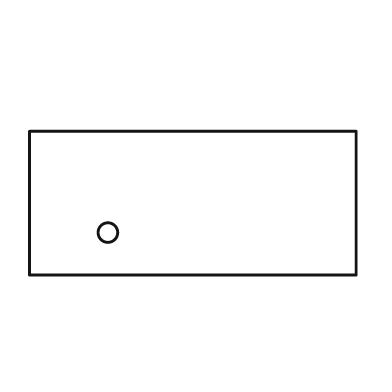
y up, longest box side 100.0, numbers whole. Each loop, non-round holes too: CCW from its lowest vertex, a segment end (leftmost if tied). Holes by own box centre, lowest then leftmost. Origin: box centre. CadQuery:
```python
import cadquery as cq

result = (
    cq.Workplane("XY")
    .moveTo(-50.0, -22.0)
    .lineTo(50.0, -22.0)
    .lineTo(50.0, 22.0)
    .lineTo(-50.0, 22.0)
    .close()
    .moveTo(-26.0, -9.0)
    .circle(3.0)
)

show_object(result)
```